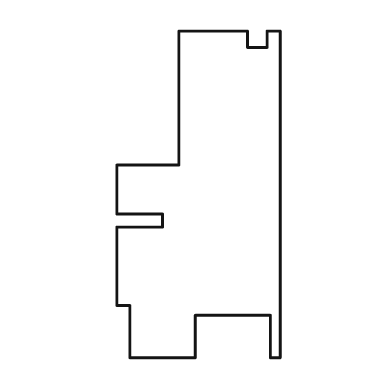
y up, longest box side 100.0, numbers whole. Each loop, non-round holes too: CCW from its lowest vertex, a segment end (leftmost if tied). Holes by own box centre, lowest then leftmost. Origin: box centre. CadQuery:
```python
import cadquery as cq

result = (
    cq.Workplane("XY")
    .moveTo(-21.0, -50.0)
    .lineTo(-1.0, -50.0)
    .lineTo(-1.0, -37.0)
    .lineTo(22.0, -37.0)
    .lineTo(22.0, -50.0)
    .lineTo(25.0, -50.0)
    .lineTo(25.0, 50.0)
    .lineTo(21.0, 50.0)
    .lineTo(21.0, 45.0)
    .lineTo(15.0, 45.0)
    .lineTo(15.0, 50.0)
    .lineTo(-6.0, 50.0)
    .lineTo(-6.0, 9.0)
    .lineTo(-25.0, 9.0)
    .lineTo(-25.0, -6.0)
    .lineTo(-11.0, -6.0)
    .lineTo(-11.0, -10.0)
    .lineTo(-25.0, -10.0)
    .lineTo(-25.0, -34.0)
    .lineTo(-21.0, -34.0)
    .close()
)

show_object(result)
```